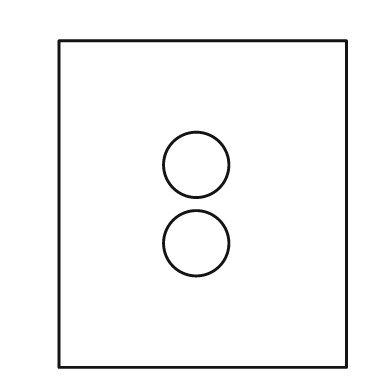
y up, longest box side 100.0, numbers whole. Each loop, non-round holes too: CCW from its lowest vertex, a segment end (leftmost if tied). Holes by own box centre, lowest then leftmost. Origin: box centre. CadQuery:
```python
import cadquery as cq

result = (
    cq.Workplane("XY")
    .moveTo(-44.0, -50.0)
    .lineTo(44.0, -50.0)
    .lineTo(44.0, 50.0)
    .lineTo(-44.0, 50.0)
    .close()
    .moveTo(-2.0, -12.0)
    .circle(10.0)
    .moveTo(-2.0, 12.0)
    .circle(10.0)
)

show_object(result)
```